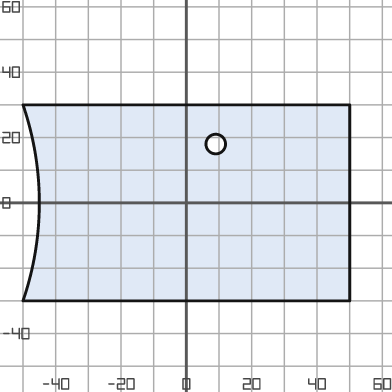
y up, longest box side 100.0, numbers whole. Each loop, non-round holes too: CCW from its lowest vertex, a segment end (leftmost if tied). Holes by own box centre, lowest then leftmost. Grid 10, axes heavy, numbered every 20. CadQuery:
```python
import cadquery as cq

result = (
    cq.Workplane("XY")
    .moveTo(-50.0, -30.0)
    .lineTo(50.0, -30.0)
    .lineTo(50.0, 30.0)
    .lineTo(-50.0, 30.0)
    .threePointArc((-45.0, 0.0), (-50.0, -30.0))
    .close()
    .moveTo(9.0, 18.0)
    .circle(3.0)
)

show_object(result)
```